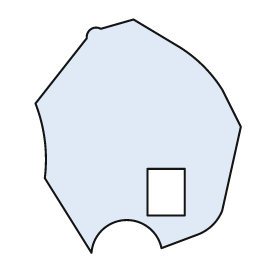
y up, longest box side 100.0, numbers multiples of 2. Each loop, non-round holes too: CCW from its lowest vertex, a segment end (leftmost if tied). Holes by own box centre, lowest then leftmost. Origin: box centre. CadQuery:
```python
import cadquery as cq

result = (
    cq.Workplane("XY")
    .moveTo(-20.0, -50.0)
    .threePointArc((-6.0, -36.0), (10.0, -48.0))
    .lineTo(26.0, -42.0)
    .threePointArc((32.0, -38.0), (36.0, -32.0))
    .lineTo(44.0, 4.0)
    .lineTo(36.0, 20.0)
    .threePointArc((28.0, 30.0), (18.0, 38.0))
    .lineTo(-2.0, 50.0)
    .lineTo(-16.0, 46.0)
    .threePointArc((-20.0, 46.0), (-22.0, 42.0))
    .lineTo(-44.0, 14.0)
    .threePointArc((-40.0, -2.0), (-40.0, -18.0))
    .close()
    .moveTo(4.0, -34.0)
    .lineTo(20.0, -34.0)
    .lineTo(20.0, -14.0)
    .lineTo(4.0, -14.0)
    .close()
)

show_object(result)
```